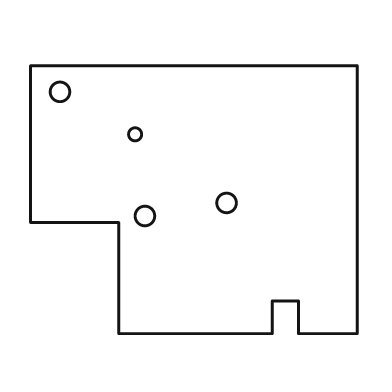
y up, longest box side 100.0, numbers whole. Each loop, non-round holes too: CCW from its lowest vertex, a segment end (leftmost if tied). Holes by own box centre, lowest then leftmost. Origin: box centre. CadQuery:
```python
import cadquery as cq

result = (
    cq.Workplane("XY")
    .moveTo(-23.0, -41.0)
    .lineTo(24.0, -41.0)
    .lineTo(24.0, -31.0)
    .lineTo(32.0, -31.0)
    .lineTo(32.0, -41.0)
    .lineTo(50.0, -41.0)
    .lineTo(50.0, 41.0)
    .lineTo(-50.0, 41.0)
    .lineTo(-50.0, -7.0)
    .lineTo(-23.0, -7.0)
    .close()
    .moveTo(-15.0, -5.0)
    .circle(3.0)
    .moveTo(10.0, -1.0)
    .circle(3.0)
    .moveTo(-18.0, 20.0)
    .circle(2.0)
    .moveTo(-41.0, 33.0)
    .circle(3.0)
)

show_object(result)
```